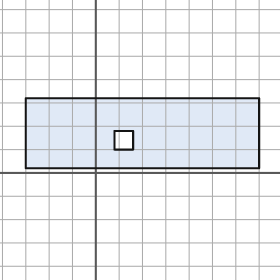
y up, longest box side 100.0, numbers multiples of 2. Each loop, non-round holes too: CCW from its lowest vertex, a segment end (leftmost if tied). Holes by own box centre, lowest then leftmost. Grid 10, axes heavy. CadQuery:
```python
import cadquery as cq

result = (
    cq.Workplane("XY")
    .moveTo(-30.0, 2.0)
    .lineTo(70.0, 2.0)
    .lineTo(70.0, 32.0)
    .lineTo(-30.0, 32.0)
    .close()
    .moveTo(8.0, 10.0)
    .lineTo(16.0, 10.0)
    .lineTo(16.0, 18.0)
    .lineTo(8.0, 18.0)
    .close()
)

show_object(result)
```